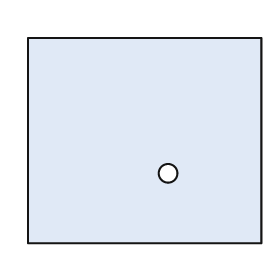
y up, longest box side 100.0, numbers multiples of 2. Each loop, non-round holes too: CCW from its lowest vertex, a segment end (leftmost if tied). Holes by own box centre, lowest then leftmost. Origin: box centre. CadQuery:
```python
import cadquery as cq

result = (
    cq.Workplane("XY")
    .moveTo(-50.0, -44.0)
    .lineTo(50.0, -44.0)
    .lineTo(50.0, 44.0)
    .lineTo(-50.0, 44.0)
    .close()
    .moveTo(10.0, -14.0)
    .circle(4.0)
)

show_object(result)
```